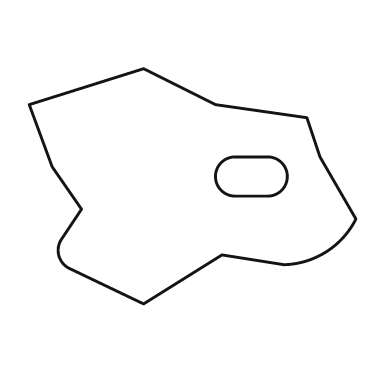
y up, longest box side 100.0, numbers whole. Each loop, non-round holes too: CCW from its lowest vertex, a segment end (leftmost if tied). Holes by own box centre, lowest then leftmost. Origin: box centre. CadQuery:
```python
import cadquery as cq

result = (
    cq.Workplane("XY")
    .moveTo(-15.0, -36.0)
    .lineTo(9.0, -21.0)
    .lineTo(28.0, -24.0)
    .threePointArc((41.0, -20.0), (50.0, -10.0))
    .lineTo(39.0, 9.0)
    .lineTo(35.0, 21.0)
    .lineTo(7.0, 25.0)
    .lineTo(-15.0, 36.0)
    .lineTo(-50.0, 25.0)
    .lineTo(-43.0, 6.0)
    .lineTo(-34.0, -7.0)
    .lineTo(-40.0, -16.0)
    .threePointArc((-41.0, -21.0), (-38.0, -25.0))
    .close()
    .moveTo(13.0, -3.0)
    .lineTo(23.0, -3.0)
    .threePointArc((29.0, 3.0), (23.0, 9.0))
    .lineTo(13.0, 9.0)
    .threePointArc((7.0, 3.0), (13.0, -3.0))
    .close()
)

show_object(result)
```